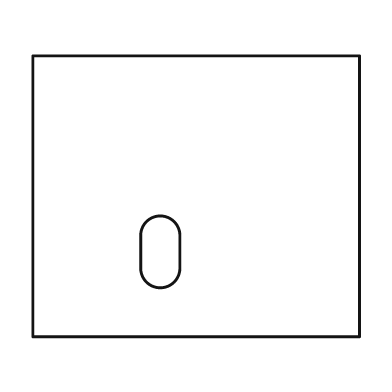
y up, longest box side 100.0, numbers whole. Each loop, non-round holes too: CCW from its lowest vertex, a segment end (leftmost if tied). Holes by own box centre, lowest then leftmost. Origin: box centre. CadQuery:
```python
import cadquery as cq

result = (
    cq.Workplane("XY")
    .moveTo(-50.0, -43.0)
    .lineTo(50.0, -43.0)
    .lineTo(50.0, 43.0)
    .lineTo(-50.0, 43.0)
    .close()
    .moveTo(-17.0, -22.0)
    .threePointArc((-11.0, -28.0), (-5.0, -22.0))
    .lineTo(-5.0, -12.0)
    .threePointArc((-11.0, -6.0), (-17.0, -12.0))
    .close()
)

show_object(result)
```